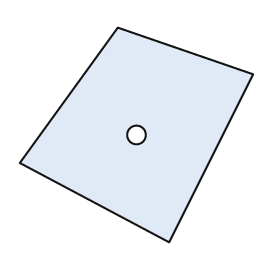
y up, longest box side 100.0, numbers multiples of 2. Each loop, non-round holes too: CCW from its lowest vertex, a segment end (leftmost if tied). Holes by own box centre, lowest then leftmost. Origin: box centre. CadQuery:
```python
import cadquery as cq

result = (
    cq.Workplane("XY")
    .moveTo(14.0, -46.0)
    .lineTo(50.0, 26.0)
    .lineTo(-8.0, 46.0)
    .lineTo(-50.0, -12.0)
    .close()
    .moveTo(0.0, 0.0)
    .circle(4.0)
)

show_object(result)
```